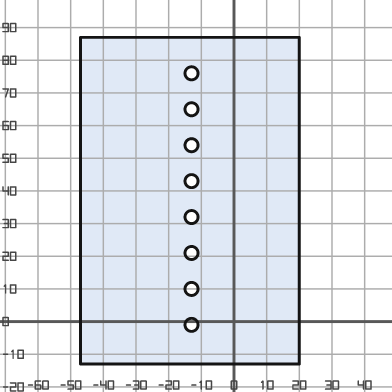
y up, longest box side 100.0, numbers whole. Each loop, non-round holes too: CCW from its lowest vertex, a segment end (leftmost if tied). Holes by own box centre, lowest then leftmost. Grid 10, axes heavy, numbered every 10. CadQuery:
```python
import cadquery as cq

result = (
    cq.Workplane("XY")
    .moveTo(-47.0, -13.0)
    .lineTo(20.0, -13.0)
    .lineTo(20.0, 87.0)
    .lineTo(-47.0, 87.0)
    .close()
    .moveTo(-13.0, -1.0)
    .circle(2.0)
    .moveTo(-13.0, 10.0)
    .circle(2.0)
    .moveTo(-13.0, 21.0)
    .circle(2.0)
    .moveTo(-13.0, 32.0)
    .circle(2.0)
    .moveTo(-13.0, 43.0)
    .circle(2.0)
    .moveTo(-13.0, 54.0)
    .circle(2.0)
    .moveTo(-13.0, 65.0)
    .circle(2.0)
    .moveTo(-13.0, 76.0)
    .circle(2.0)
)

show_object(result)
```